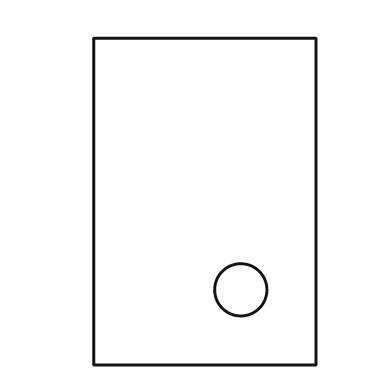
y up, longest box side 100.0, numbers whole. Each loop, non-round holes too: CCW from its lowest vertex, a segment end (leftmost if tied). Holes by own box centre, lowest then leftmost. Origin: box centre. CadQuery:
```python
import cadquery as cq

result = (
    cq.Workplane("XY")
    .moveTo(-34.0, -50.0)
    .lineTo(34.0, -50.0)
    .lineTo(34.0, 50.0)
    .lineTo(-34.0, 50.0)
    .close()
    .moveTo(11.0, -27.0)
    .circle(8.0)
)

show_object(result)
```